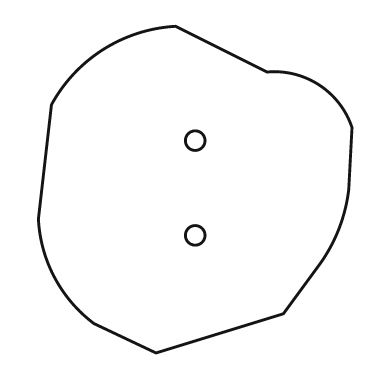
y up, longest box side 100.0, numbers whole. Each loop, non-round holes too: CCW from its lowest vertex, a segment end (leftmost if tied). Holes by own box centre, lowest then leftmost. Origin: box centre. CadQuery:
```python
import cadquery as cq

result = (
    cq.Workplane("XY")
    .moveTo(-12.0, -50.0)
    .lineTo(27.0, -38.0)
    .lineTo(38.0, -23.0)
    .threePointArc((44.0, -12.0), (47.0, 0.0))
    .lineTo(48.0, 19.0)
    .threePointArc((38.0, 32.0), (22.0, 36.0))
    .lineTo(-6.0, 50.0)
    .threePointArc((-28.0, 43.0), (-44.0, 26.0))
    .lineTo(-48.0, -9.0)
    .threePointArc((-43.0, -27.0), (-31.0, -41.0))
    .close()
    .moveTo(0.0, -14.0)
    .circle(3.0)
    .moveTo(0.0, 15.0)
    .circle(3.0)
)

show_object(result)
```